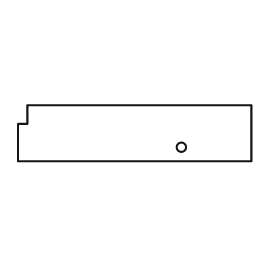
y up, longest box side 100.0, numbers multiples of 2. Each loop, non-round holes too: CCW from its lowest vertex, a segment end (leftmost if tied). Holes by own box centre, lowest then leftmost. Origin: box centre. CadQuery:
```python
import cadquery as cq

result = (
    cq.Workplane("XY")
    .moveTo(-50.0, -12.0)
    .lineTo(50.0, -12.0)
    .lineTo(50.0, 12.0)
    .lineTo(-46.0, 12.0)
    .lineTo(-46.0, 4.0)
    .lineTo(-50.0, 4.0)
    .close()
    .moveTo(20.0, -6.0)
    .circle(2.0)
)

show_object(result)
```